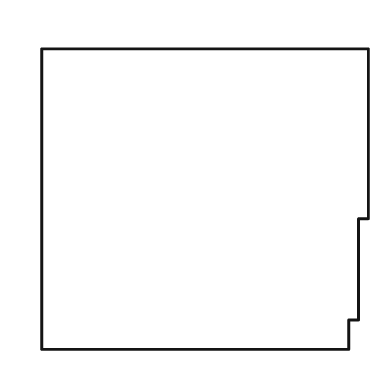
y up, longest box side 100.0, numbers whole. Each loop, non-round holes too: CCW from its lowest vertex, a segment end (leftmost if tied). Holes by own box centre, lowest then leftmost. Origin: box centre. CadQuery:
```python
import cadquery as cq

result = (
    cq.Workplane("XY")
    .moveTo(-50.0, -46.0)
    .lineTo(44.0, -46.0)
    .lineTo(44.0, -37.0)
    .lineTo(47.0, -37.0)
    .lineTo(47.0, -6.0)
    .lineTo(50.0, -6.0)
    .lineTo(50.0, 46.0)
    .lineTo(-50.0, 46.0)
    .close()
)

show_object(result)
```